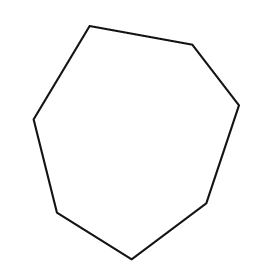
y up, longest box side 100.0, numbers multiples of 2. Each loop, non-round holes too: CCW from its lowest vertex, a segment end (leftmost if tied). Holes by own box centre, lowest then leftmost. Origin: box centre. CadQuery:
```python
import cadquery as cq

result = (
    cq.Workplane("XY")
    .moveTo(-2.0, -50.0)
    .lineTo(30.0, -26.0)
    .lineTo(44.0, 16.0)
    .lineTo(24.0, 42.0)
    .lineTo(-20.0, 50.0)
    .lineTo(-44.0, 10.0)
    .lineTo(-34.0, -30.0)
    .close()
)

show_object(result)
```